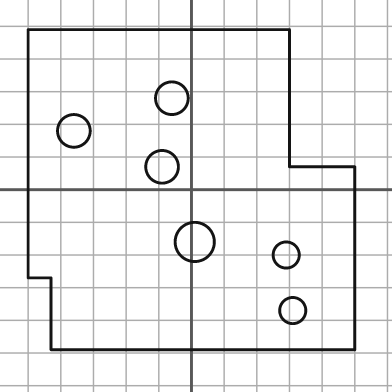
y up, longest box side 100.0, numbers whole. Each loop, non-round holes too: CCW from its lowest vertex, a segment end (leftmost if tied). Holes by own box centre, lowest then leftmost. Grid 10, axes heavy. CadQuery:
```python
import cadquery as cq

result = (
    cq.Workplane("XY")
    .moveTo(-43.0, -49.0)
    .lineTo(50.0, -49.0)
    .lineTo(50.0, 7.0)
    .lineTo(30.0, 7.0)
    .lineTo(30.0, 49.0)
    .lineTo(-50.0, 49.0)
    .lineTo(-50.0, -27.0)
    .lineTo(-43.0, -27.0)
    .close()
    .moveTo(31.0, -37.0)
    .circle(4.0)
    .moveTo(29.0, -20.0)
    .circle(4.0)
    .moveTo(1.0, -16.0)
    .circle(6.0)
    .moveTo(-9.0, 7.0)
    .circle(5.0)
    .moveTo(-36.0, 18.0)
    .circle(5.0)
    .moveTo(-6.0, 28.0)
    .circle(5.0)
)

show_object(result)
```